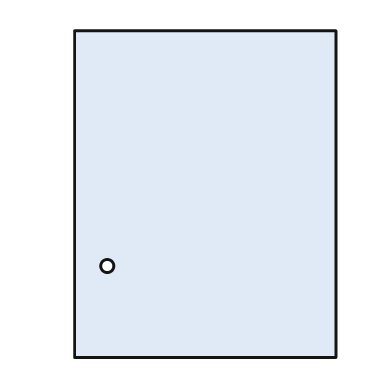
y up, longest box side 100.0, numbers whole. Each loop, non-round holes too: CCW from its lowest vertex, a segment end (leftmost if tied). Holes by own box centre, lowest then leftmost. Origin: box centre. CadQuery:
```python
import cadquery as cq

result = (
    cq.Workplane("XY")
    .moveTo(-40.0, -50.0)
    .lineTo(40.0, -50.0)
    .lineTo(40.0, 50.0)
    .lineTo(-40.0, 50.0)
    .close()
    .moveTo(-30.0, -22.0)
    .circle(2.0)
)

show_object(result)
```